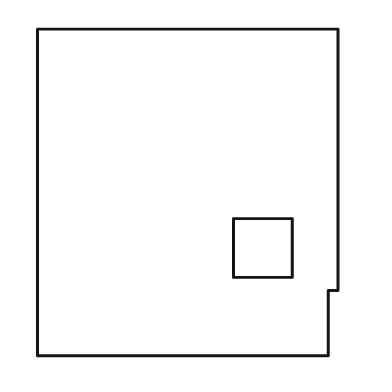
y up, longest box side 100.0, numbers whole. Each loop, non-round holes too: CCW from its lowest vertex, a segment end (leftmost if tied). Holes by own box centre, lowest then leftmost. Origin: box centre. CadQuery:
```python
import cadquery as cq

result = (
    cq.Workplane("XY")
    .moveTo(-46.0, -50.0)
    .lineTo(43.0, -50.0)
    .lineTo(43.0, -30.0)
    .lineTo(46.0, -30.0)
    .lineTo(46.0, 50.0)
    .lineTo(-46.0, 50.0)
    .close()
    .moveTo(14.0, -26.0)
    .lineTo(32.0, -26.0)
    .lineTo(32.0, -8.0)
    .lineTo(14.0, -8.0)
    .close()
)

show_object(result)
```